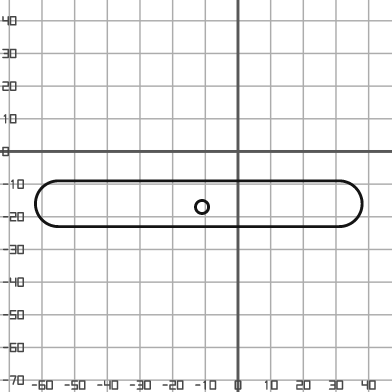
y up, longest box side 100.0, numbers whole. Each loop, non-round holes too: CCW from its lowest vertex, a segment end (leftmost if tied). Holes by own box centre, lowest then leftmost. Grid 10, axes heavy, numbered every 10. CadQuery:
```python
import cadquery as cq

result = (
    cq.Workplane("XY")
    .moveTo(-55.0, -23.0)
    .lineTo(31.0, -23.0)
    .threePointArc((38.0, -16.0), (31.0, -9.0))
    .lineTo(-55.0, -9.0)
    .threePointArc((-62.0, -16.0), (-55.0, -23.0))
    .close()
    .moveTo(-11.0, -17.0)
    .circle(2.0)
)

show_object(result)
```